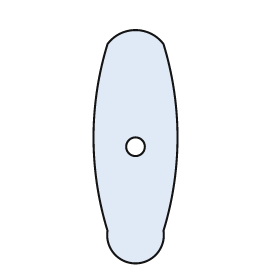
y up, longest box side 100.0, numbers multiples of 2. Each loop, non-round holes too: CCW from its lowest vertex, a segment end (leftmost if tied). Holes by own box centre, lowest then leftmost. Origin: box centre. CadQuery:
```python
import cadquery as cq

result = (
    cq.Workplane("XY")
    .moveTo(-12.0, -36.0)
    .threePointArc((0.0, -50.0), (12.0, -36.0))
    .threePointArc((18.0, 4.0), (12.0, 44.0))
    .threePointArc((0.0, 50.0), (-12.0, 44.0))
    .threePointArc((-18.0, 4.0), (-12.0, -36.0))
    .close()
    .moveTo(0.0, 0.0)
    .circle(4.0)
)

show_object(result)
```